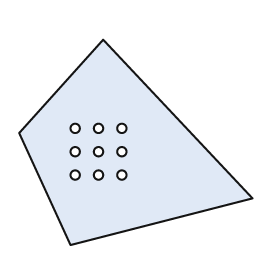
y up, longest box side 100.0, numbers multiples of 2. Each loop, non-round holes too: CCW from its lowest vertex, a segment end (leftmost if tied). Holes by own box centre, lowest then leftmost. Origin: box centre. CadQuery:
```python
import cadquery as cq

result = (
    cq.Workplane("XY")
    .moveTo(-28.0, -44.0)
    .lineTo(50.0, -24.0)
    .lineTo(-14.0, 44.0)
    .lineTo(-50.0, 4.0)
    .close()
    .moveTo(-26.0, -14.0)
    .circle(2.0)
    .moveTo(-16.0, -14.0)
    .circle(2.0)
    .moveTo(-6.0, -14.0)
    .circle(2.0)
    .moveTo(-26.0, -4.0)
    .circle(2.0)
    .moveTo(-16.0, -4.0)
    .circle(2.0)
    .moveTo(-6.0, -4.0)
    .circle(2.0)
    .moveTo(-26.0, 6.0)
    .circle(2.0)
    .moveTo(-16.0, 6.0)
    .circle(2.0)
    .moveTo(-6.0, 6.0)
    .circle(2.0)
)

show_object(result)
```